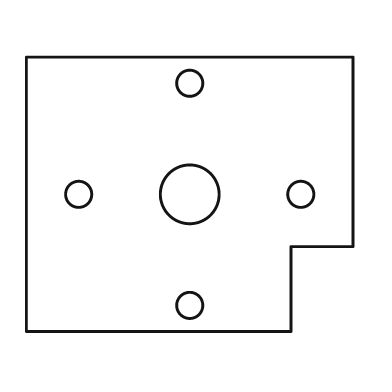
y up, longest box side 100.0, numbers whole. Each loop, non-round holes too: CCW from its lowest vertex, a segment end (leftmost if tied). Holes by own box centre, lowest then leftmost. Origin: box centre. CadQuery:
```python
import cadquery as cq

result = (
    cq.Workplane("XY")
    .moveTo(-50.0, -42.0)
    .lineTo(31.0, -42.0)
    .lineTo(31.0, -16.0)
    .lineTo(50.0, -16.0)
    .lineTo(50.0, 42.0)
    .lineTo(-50.0, 42.0)
    .close()
    .moveTo(0.0, -34.0)
    .circle(4.0)
    .moveTo(-34.0, 0.0)
    .circle(4.0)
    .moveTo(0.0, 0.0)
    .circle(9.0)
    .moveTo(34.0, 0.0)
    .circle(4.0)
    .moveTo(0.0, 34.0)
    .circle(4.0)
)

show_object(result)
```